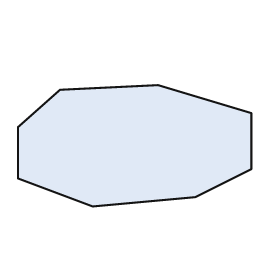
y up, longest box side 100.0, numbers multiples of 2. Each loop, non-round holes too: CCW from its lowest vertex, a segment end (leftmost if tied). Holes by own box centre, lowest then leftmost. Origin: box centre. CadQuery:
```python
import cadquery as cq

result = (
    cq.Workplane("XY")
    .moveTo(-18.0, -26.0)
    .lineTo(26.0, -22.0)
    .lineTo(50.0, -10.0)
    .lineTo(50.0, 14.0)
    .lineTo(10.0, 26.0)
    .lineTo(-32.0, 24.0)
    .lineTo(-50.0, 8.0)
    .lineTo(-50.0, -14.0)
    .close()
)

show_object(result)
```